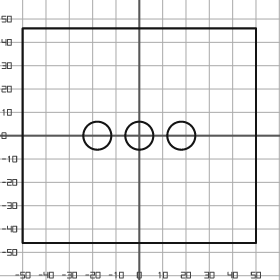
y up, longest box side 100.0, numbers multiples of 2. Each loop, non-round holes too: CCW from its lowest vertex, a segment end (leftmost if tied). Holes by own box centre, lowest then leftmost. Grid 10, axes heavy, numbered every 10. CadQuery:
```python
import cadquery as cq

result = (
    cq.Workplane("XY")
    .moveTo(-50.0, -46.0)
    .lineTo(50.0, -46.0)
    .lineTo(50.0, 46.0)
    .lineTo(-50.0, 46.0)
    .close()
    .moveTo(-18.0, 0.0)
    .circle(6.0)
    .moveTo(0.0, 0.0)
    .circle(6.0)
    .moveTo(18.0, 0.0)
    .circle(6.0)
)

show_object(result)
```